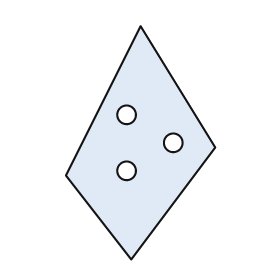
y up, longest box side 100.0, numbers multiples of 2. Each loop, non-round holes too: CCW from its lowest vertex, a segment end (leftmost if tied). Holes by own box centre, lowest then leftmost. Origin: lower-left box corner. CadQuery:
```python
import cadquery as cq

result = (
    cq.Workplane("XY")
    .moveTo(28.0, 0.0)
    .lineTo(64.0, 48.0)
    .lineTo(32.0, 100.0)
    .lineTo(0.0, 36.0)
    .close()
    .moveTo(26.0, 38.0)
    .circle(4.0)
    .moveTo(46.0, 50.0)
    .circle(4.0)
    .moveTo(26.0, 62.0)
    .circle(4.0)
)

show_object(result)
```